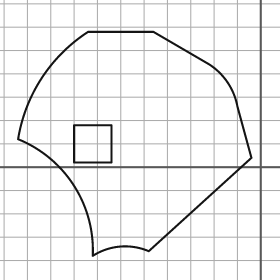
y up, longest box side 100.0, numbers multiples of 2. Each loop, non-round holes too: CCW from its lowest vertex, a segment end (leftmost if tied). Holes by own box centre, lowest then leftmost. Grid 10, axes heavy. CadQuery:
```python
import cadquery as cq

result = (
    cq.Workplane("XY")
    .moveTo(-72.0, -38.0)
    .threePointArc((-60.0, -34.0), (-48.0, -36.0))
    .lineTo(-4.0, 4.0)
    .lineTo(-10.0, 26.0)
    .threePointArc((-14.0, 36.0), (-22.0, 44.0))
    .lineTo(-46.0, 58.0)
    .lineTo(-74.0, 58.0)
    .threePointArc((-94.0, 38.0), (-104.0, 12.0))
    .threePointArc((-80.0, -8.0), (-72.0, -38.0))
    .close()
    .moveTo(-80.0, 2.0)
    .lineTo(-64.0, 2.0)
    .lineTo(-64.0, 18.0)
    .lineTo(-80.0, 18.0)
    .close()
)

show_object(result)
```